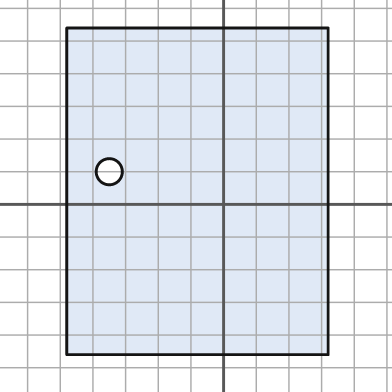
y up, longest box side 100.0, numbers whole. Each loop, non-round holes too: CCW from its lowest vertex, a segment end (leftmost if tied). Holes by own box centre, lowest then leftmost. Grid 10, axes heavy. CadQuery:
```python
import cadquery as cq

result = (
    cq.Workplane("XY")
    .moveTo(-48.0, -46.0)
    .lineTo(32.0, -46.0)
    .lineTo(32.0, 54.0)
    .lineTo(-48.0, 54.0)
    .close()
    .moveTo(-35.0, 10.0)
    .circle(4.0)
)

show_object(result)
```